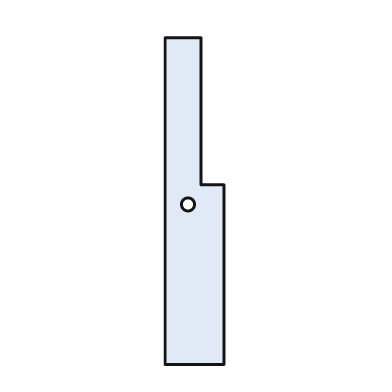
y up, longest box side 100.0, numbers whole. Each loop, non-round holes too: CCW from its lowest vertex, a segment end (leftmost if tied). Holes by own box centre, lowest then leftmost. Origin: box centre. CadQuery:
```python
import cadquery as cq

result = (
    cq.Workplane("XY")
    .moveTo(-9.0, -50.0)
    .lineTo(9.0, -50.0)
    .lineTo(9.0, 5.0)
    .lineTo(2.0, 5.0)
    .lineTo(2.0, 50.0)
    .lineTo(-9.0, 50.0)
    .close()
    .moveTo(-2.0, -1.0)
    .circle(2.0)
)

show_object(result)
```